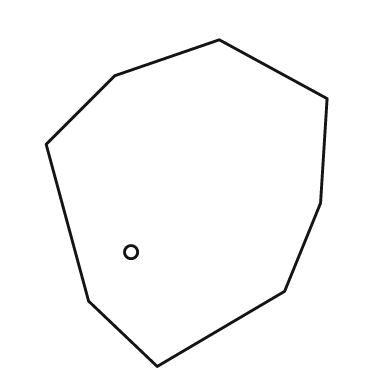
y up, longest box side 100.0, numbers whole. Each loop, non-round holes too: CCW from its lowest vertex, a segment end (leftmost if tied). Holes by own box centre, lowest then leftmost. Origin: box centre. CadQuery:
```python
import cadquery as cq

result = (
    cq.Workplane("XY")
    .moveTo(-9.0, -50.0)
    .lineTo(30.0, -27.0)
    .lineTo(41.0, 0.0)
    .lineTo(43.0, 32.0)
    .lineTo(10.0, 50.0)
    .lineTo(-22.0, 39.0)
    .lineTo(-43.0, 18.0)
    .lineTo(-30.0, -30.0)
    .close()
    .moveTo(-17.0, -15.0)
    .circle(2.0)
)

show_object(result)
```